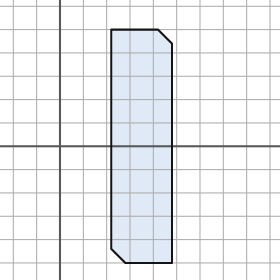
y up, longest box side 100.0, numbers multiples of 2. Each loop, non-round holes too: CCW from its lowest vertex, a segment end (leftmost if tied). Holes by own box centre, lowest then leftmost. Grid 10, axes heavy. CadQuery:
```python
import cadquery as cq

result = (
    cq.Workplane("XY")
    .moveTo(28.0, -50.0)
    .lineTo(48.0, -50.0)
    .lineTo(48.0, 44.0)
    .lineTo(42.0, 50.0)
    .lineTo(22.0, 50.0)
    .lineTo(22.0, -44.0)
    .close()
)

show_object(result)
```